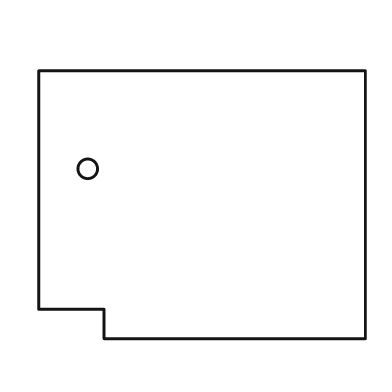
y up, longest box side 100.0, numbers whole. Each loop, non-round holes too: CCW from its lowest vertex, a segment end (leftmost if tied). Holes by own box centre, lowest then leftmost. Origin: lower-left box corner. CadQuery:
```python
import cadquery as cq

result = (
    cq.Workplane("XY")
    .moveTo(20.0, 0.0)
    .lineTo(100.0, 0.0)
    .lineTo(100.0, 82.0)
    .lineTo(0.0, 82.0)
    .lineTo(0.0, 9.0)
    .lineTo(20.0, 9.0)
    .close()
    .moveTo(15.0, 52.0)
    .circle(3.0)
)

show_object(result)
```